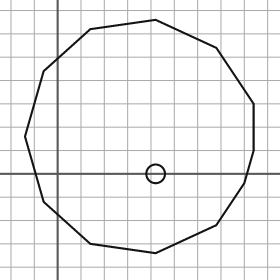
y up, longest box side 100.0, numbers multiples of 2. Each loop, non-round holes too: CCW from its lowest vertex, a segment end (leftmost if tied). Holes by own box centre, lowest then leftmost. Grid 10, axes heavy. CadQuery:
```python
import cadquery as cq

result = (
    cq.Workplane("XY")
    .moveTo(42.0, -34.0)
    .lineTo(68.0, -22.0)
    .lineTo(80.0, -4.0)
    .lineTo(84.0, 10.0)
    .lineTo(84.0, 30.0)
    .lineTo(68.0, 54.0)
    .lineTo(42.0, 66.0)
    .lineTo(14.0, 62.0)
    .lineTo(-6.0, 44.0)
    .lineTo(-14.0, 16.0)
    .lineTo(-6.0, -12.0)
    .lineTo(14.0, -30.0)
    .close()
    .moveTo(42.0, 0.0)
    .circle(4.0)
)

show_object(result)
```